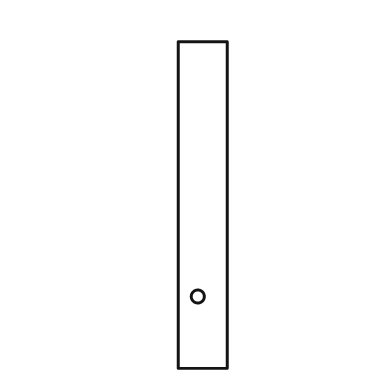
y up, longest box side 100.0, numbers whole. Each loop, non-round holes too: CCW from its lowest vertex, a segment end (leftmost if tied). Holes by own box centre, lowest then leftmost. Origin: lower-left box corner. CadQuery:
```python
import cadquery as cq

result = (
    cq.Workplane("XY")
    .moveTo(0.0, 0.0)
    .lineTo(15.0, 0.0)
    .lineTo(15.0, 100.0)
    .lineTo(0.0, 100.0)
    .close()
    .moveTo(6.0, 22.0)
    .circle(2.0)
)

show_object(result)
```